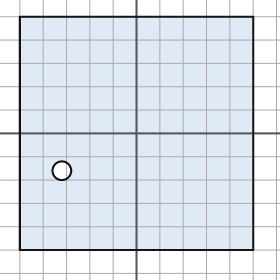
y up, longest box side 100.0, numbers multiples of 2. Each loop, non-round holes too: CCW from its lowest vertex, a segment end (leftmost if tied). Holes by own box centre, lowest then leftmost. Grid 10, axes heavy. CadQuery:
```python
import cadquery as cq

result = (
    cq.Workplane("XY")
    .moveTo(-50.0, -50.0)
    .lineTo(50.0, -50.0)
    .lineTo(50.0, 50.0)
    .lineTo(-50.0, 50.0)
    .close()
    .moveTo(-32.0, -16.0)
    .circle(4.0)
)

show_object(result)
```